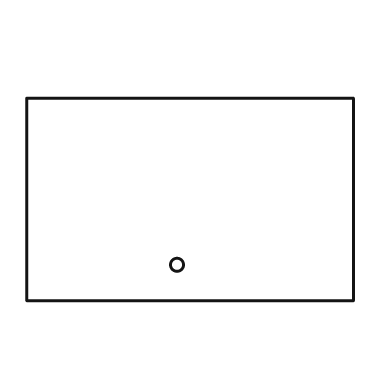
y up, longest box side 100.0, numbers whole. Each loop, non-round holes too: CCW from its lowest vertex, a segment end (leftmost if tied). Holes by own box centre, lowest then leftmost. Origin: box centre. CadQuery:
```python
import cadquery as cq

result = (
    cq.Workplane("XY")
    .moveTo(-50.0, -31.0)
    .lineTo(50.0, -31.0)
    .lineTo(50.0, 31.0)
    .lineTo(-50.0, 31.0)
    .close()
    .moveTo(-4.0, -20.0)
    .circle(2.0)
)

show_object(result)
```